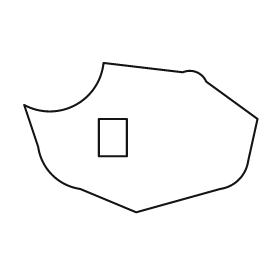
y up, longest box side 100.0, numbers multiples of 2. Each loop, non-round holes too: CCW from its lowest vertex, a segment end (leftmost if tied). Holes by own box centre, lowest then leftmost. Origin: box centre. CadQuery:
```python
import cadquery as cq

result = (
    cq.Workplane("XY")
    .moveTo(-2.0, -32.0)
    .lineTo(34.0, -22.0)
    .threePointArc((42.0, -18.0), (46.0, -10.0))
    .lineTo(50.0, 8.0)
    .lineTo(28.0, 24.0)
    .threePointArc((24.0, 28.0), (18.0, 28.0))
    .lineTo(-16.0, 32.0)
    .threePointArc((-28.0, 14.0), (-50.0, 14.0))
    .lineTo(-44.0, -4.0)
    .threePointArc((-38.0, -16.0), (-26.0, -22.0))
    .close()
    .moveTo(-18.0, -8.0)
    .lineTo(-6.0, -8.0)
    .lineTo(-6.0, 8.0)
    .lineTo(-18.0, 8.0)
    .close()
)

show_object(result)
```